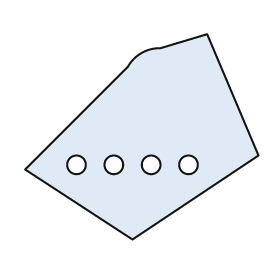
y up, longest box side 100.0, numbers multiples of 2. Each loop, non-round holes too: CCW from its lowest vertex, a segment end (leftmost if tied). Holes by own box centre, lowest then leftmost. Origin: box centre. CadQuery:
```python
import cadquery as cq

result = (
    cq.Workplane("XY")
    .moveTo(-4.0, -44.0)
    .lineTo(50.0, -8.0)
    .lineTo(28.0, 44.0)
    .lineTo(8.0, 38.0)
    .threePointArc((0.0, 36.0), (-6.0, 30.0))
    .lineTo(-50.0, -14.0)
    .close()
    .moveTo(-28.0, -12.0)
    .circle(4.0)
    .moveTo(-12.0, -12.0)
    .circle(4.0)
    .moveTo(4.0, -12.0)
    .circle(4.0)
    .moveTo(20.0, -12.0)
    .circle(4.0)
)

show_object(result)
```